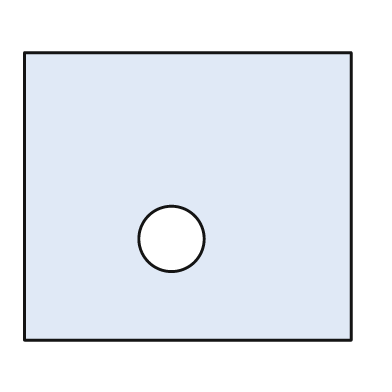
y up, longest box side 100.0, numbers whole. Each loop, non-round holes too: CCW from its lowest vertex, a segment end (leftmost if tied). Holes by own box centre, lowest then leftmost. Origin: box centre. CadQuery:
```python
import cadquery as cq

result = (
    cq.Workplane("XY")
    .moveTo(-50.0, -44.0)
    .lineTo(50.0, -44.0)
    .lineTo(50.0, 44.0)
    .lineTo(-50.0, 44.0)
    .close()
    .moveTo(-5.0, -13.0)
    .circle(10.0)
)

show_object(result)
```